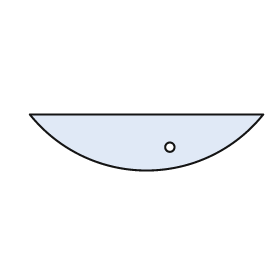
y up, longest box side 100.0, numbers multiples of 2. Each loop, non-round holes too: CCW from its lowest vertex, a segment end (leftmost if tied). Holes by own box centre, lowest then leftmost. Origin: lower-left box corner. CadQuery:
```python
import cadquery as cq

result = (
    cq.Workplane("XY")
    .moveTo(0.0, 24.0)
    .threePointArc((50.0, 0.0), (100.0, 24.0))
    .close()
    .moveTo(60.0, 10.0)
    .circle(2.0)
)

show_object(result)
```